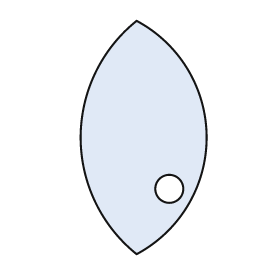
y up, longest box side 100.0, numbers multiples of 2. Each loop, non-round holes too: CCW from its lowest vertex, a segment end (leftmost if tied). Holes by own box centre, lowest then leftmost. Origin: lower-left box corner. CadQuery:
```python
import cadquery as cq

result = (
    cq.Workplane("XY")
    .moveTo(24.0, 0.0)
    .threePointArc((54.0, 50.0), (24.0, 100.0))
    .threePointArc((0.0, 50.0), (24.0, 0.0))
    .close()
    .moveTo(38.0, 28.0)
    .circle(6.0)
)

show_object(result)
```